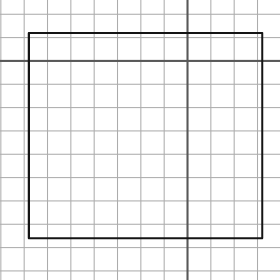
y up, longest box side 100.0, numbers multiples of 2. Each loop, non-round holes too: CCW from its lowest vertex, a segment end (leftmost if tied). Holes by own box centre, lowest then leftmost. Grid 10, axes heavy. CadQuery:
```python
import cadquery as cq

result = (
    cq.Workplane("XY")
    .moveTo(-68.0, -76.0)
    .lineTo(32.0, -76.0)
    .lineTo(32.0, 12.0)
    .lineTo(-68.0, 12.0)
    .close()
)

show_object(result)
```